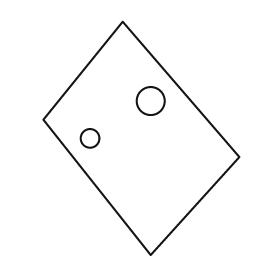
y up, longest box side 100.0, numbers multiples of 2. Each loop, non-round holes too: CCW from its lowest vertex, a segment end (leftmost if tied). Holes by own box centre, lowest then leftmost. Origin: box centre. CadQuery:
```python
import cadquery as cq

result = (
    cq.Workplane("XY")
    .moveTo(4.0, -50.0)
    .lineTo(42.0, -8.0)
    .lineTo(-8.0, 50.0)
    .lineTo(-42.0, 8.0)
    .close()
    .moveTo(-22.0, 0.0)
    .circle(4.0)
    .moveTo(4.0, 16.0)
    .circle(6.0)
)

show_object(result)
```